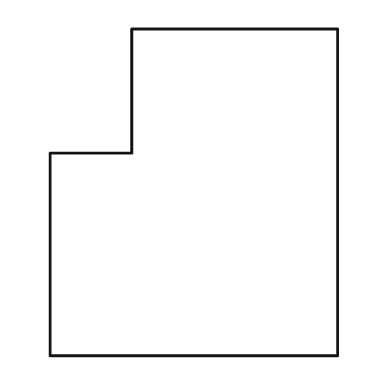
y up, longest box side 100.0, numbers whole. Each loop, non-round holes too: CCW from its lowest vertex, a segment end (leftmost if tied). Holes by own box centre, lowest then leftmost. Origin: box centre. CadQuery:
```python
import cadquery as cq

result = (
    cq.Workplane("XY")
    .moveTo(-44.0, -50.0)
    .lineTo(44.0, -50.0)
    .lineTo(44.0, 50.0)
    .lineTo(-19.0, 50.0)
    .lineTo(-19.0, 12.0)
    .lineTo(-44.0, 12.0)
    .close()
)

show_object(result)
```